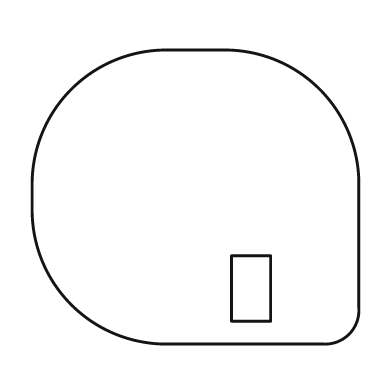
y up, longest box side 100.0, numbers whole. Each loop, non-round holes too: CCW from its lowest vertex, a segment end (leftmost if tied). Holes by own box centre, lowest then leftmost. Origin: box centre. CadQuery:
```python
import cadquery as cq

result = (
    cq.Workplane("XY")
    .moveTo(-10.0, -45.0)
    .lineTo(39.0, -45.0)
    .threePointArc((47.0, -42.0), (50.0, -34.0))
    .lineTo(50.0, 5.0)
    .threePointArc((38.0, 33.0), (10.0, 45.0))
    .lineTo(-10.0, 45.0)
    .threePointArc((-38.0, 33.0), (-50.0, 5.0))
    .lineTo(-50.0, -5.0)
    .threePointArc((-38.0, -33.0), (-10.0, -45.0))
    .close()
    .moveTo(11.0, -38.0)
    .lineTo(23.0, -38.0)
    .lineTo(23.0, -18.0)
    .lineTo(11.0, -18.0)
    .close()
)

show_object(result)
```